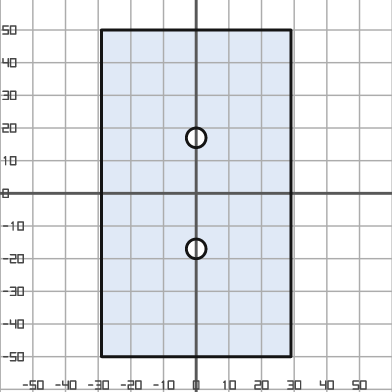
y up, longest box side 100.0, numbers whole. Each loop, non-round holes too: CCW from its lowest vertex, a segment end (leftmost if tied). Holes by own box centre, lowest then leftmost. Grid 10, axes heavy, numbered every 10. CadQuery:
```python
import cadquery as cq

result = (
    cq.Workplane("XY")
    .moveTo(-29.0, -50.0)
    .lineTo(29.0, -50.0)
    .lineTo(29.0, 50.0)
    .lineTo(-29.0, 50.0)
    .close()
    .moveTo(0.0, -17.0)
    .circle(3.0)
    .moveTo(0.0, 17.0)
    .circle(3.0)
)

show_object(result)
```